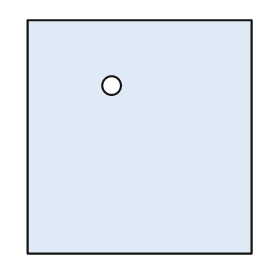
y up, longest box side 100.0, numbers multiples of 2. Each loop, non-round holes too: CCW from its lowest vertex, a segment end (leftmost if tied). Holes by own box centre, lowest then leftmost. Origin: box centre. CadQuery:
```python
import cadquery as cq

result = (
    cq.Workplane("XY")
    .moveTo(-48.0, -50.0)
    .lineTo(48.0, -50.0)
    .lineTo(48.0, 50.0)
    .lineTo(-48.0, 50.0)
    .close()
    .moveTo(-12.0, 22.0)
    .circle(4.0)
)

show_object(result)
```